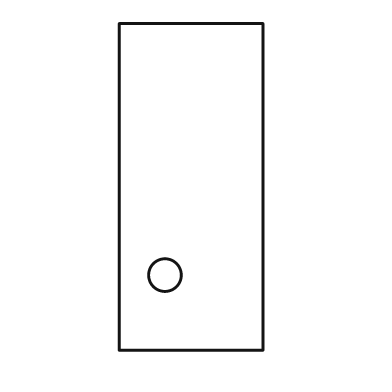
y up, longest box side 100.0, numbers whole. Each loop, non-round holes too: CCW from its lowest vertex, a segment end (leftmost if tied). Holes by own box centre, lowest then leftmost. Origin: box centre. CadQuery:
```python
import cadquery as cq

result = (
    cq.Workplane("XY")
    .moveTo(-22.0, -50.0)
    .lineTo(22.0, -50.0)
    .lineTo(22.0, 50.0)
    .lineTo(-22.0, 50.0)
    .close()
    .moveTo(-8.0, -27.0)
    .circle(5.0)
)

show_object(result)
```